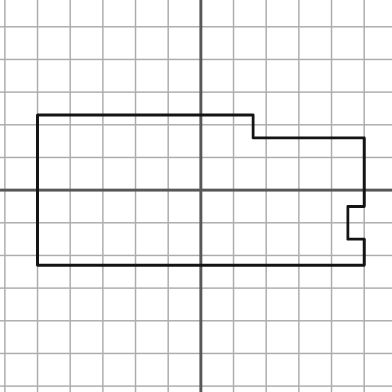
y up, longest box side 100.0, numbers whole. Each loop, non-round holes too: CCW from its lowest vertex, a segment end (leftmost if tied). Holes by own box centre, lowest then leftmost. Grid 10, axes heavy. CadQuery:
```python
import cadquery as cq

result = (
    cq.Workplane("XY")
    .moveTo(-50.0, -23.0)
    .lineTo(50.0, -23.0)
    .lineTo(50.0, -15.0)
    .lineTo(45.0, -15.0)
    .lineTo(45.0, -5.0)
    .lineTo(50.0, -5.0)
    .lineTo(50.0, 16.0)
    .lineTo(16.0, 16.0)
    .lineTo(16.0, 23.0)
    .lineTo(-50.0, 23.0)
    .close()
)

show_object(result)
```